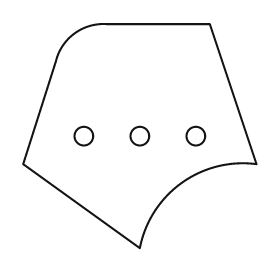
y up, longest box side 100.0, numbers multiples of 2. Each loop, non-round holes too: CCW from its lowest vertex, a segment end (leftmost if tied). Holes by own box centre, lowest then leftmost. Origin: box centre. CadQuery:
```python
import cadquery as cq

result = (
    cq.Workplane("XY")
    .moveTo(0.0, -48.0)
    .threePointArc((18.0, -20.0), (50.0, -12.0))
    .lineTo(30.0, 48.0)
    .lineTo(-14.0, 48.0)
    .threePointArc((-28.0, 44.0), (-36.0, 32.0))
    .lineTo(-50.0, -12.0)
    .close()
    .moveTo(-24.0, 0.0)
    .circle(4.0)
    .moveTo(0.0, 0.0)
    .circle(4.0)
    .moveTo(24.0, 0.0)
    .circle(4.0)
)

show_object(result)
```